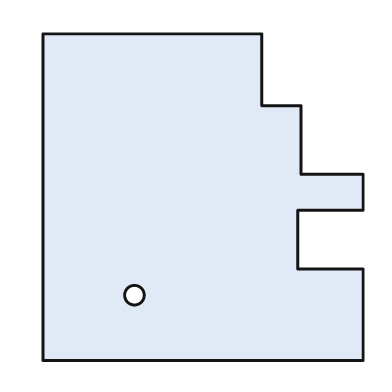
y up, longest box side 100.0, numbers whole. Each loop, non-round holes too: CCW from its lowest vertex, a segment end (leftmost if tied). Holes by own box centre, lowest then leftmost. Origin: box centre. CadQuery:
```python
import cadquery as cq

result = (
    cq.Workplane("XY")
    .moveTo(-49.0, -50.0)
    .lineTo(49.0, -50.0)
    .lineTo(49.0, -22.0)
    .lineTo(29.0, -22.0)
    .lineTo(29.0, -4.0)
    .lineTo(49.0, -4.0)
    .lineTo(49.0, 7.0)
    .lineTo(30.0, 7.0)
    .lineTo(30.0, 28.0)
    .lineTo(18.0, 28.0)
    .lineTo(18.0, 50.0)
    .lineTo(-49.0, 50.0)
    .close()
    .moveTo(-21.0, -30.0)
    .circle(3.0)
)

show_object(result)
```